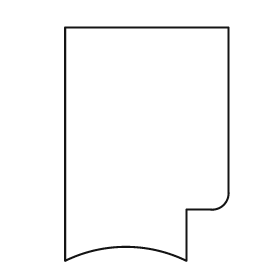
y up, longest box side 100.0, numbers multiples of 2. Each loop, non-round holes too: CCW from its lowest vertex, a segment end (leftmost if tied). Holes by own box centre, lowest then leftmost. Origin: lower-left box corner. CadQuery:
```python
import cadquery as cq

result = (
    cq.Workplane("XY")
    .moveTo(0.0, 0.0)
    .threePointArc((26.0, 6.0), (52.0, 0.0))
    .lineTo(52.0, 22.0)
    .lineTo(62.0, 22.0)
    .threePointArc((68.0, 24.0), (70.0, 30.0))
    .lineTo(70.0, 100.0)
    .lineTo(0.0, 100.0)
    .close()
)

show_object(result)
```